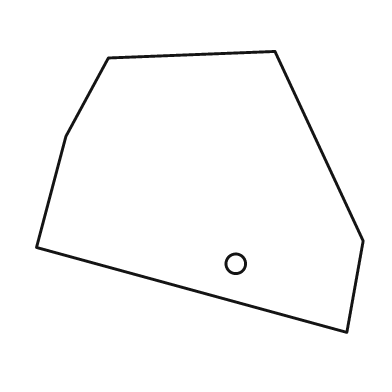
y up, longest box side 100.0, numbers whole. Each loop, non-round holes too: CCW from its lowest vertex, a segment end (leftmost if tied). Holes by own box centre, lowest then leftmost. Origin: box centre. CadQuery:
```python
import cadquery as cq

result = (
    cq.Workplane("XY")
    .moveTo(45.0, -43.0)
    .lineTo(50.0, -15.0)
    .lineTo(23.0, 43.0)
    .lineTo(-28.0, 41.0)
    .lineTo(-41.0, 17.0)
    .lineTo(-50.0, -17.0)
    .close()
    .moveTo(11.0, -22.0)
    .circle(3.0)
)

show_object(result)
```